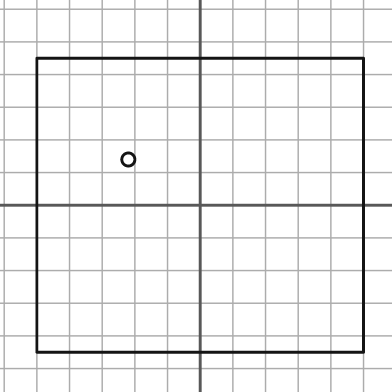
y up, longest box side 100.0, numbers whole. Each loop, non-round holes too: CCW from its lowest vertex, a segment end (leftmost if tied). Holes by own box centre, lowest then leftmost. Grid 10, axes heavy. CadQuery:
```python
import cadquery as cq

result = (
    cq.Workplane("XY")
    .moveTo(-50.0, -45.0)
    .lineTo(50.0, -45.0)
    .lineTo(50.0, 45.0)
    .lineTo(-50.0, 45.0)
    .close()
    .moveTo(-22.0, 14.0)
    .circle(2.0)
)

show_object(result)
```